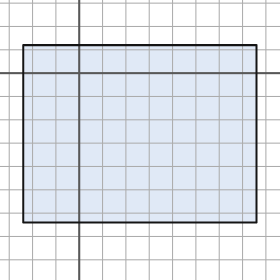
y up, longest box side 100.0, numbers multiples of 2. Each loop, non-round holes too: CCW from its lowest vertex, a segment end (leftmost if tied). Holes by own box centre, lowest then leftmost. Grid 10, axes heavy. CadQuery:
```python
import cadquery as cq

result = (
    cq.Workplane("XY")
    .moveTo(-24.0, -64.0)
    .lineTo(76.0, -64.0)
    .lineTo(76.0, 12.0)
    .lineTo(-24.0, 12.0)
    .close()
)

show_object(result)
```